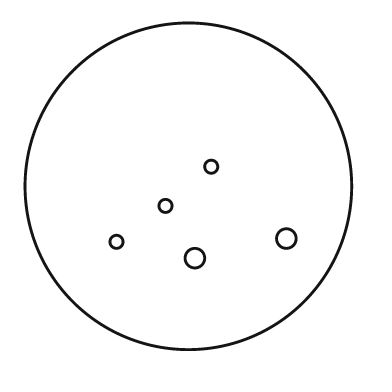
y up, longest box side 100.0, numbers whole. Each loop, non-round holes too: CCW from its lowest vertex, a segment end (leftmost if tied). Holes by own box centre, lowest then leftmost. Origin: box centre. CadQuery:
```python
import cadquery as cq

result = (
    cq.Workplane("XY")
    .moveTo(0.0, 0.0)
    .circle(50.0)
    .moveTo(2.0, -22.0)
    .circle(3.0)
    .moveTo(-22.0, -17.0)
    .circle(2.0)
    .moveTo(30.0, -16.0)
    .circle(3.0)
    .moveTo(-7.0, -6.0)
    .circle(2.0)
    .moveTo(7.0, 6.0)
    .circle(2.0)
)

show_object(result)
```